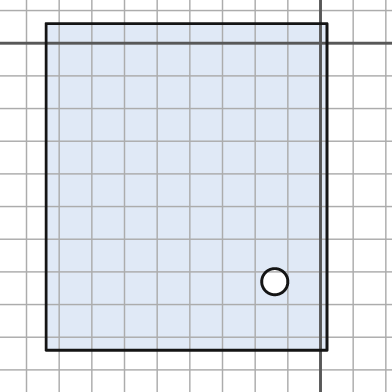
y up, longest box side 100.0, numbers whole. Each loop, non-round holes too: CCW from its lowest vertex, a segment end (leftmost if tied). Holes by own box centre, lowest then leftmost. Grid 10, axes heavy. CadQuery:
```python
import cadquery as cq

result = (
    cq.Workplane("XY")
    .moveTo(-84.0, -94.0)
    .lineTo(2.0, -94.0)
    .lineTo(2.0, 6.0)
    .lineTo(-84.0, 6.0)
    .close()
    .moveTo(-14.0, -73.0)
    .circle(4.0)
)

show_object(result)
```